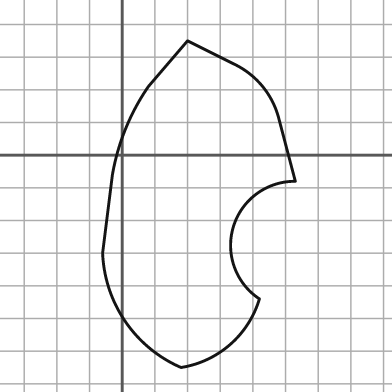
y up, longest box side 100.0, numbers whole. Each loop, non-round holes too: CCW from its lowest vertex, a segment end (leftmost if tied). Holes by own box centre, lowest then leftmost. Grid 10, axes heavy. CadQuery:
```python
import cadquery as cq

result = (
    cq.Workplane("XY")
    .moveTo(18.0, -65.0)
    .threePointArc((33.0, -58.0), (42.0, -44.0))
    .threePointArc((34.0, -22.0), (53.0, -8.0))
    .lineTo(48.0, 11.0)
    .threePointArc((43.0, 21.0), (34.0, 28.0))
    .lineTo(20.0, 35.0)
    .lineTo(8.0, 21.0)
    .threePointArc((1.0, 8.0), (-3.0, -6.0))
    .lineTo(-6.0, -30.0)
    .threePointArc((1.0, -51.0), (18.0, -65.0))
    .close()
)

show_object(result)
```